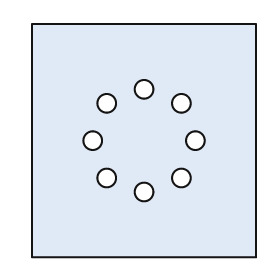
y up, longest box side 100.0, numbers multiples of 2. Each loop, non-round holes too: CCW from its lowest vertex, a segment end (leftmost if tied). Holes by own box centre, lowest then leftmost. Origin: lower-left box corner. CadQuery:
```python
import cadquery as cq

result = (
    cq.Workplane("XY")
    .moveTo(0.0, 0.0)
    .lineTo(96.0, 0.0)
    .lineTo(96.0, 100.0)
    .lineTo(0.0, 100.0)
    .close()
    .moveTo(48.0, 28.0)
    .circle(4.0)
    .moveTo(32.0, 34.0)
    .circle(4.0)
    .moveTo(64.0, 34.0)
    .circle(4.0)
    .moveTo(26.0, 50.0)
    .circle(4.0)
    .moveTo(70.0, 50.0)
    .circle(4.0)
    .moveTo(32.0, 66.0)
    .circle(4.0)
    .moveTo(64.0, 66.0)
    .circle(4.0)
    .moveTo(48.0, 72.0)
    .circle(4.0)
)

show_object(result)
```